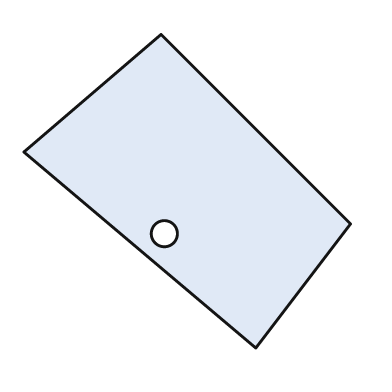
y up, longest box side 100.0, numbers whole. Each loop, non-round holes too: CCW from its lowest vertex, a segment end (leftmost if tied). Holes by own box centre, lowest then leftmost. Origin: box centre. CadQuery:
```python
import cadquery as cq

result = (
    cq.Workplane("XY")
    .moveTo(21.0, -48.0)
    .lineTo(50.0, -10.0)
    .lineTo(-8.0, 48.0)
    .lineTo(-50.0, 12.0)
    .close()
    .moveTo(-7.0, -13.0)
    .circle(4.0)
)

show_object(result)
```